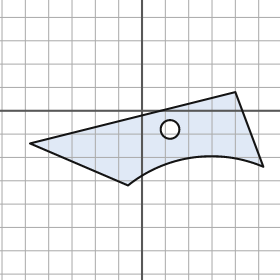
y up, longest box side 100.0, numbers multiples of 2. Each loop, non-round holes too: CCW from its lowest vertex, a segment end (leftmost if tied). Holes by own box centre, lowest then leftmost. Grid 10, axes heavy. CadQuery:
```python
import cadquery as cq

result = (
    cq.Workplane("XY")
    .moveTo(-6.0, -32.0)
    .threePointArc((22.0, -20.0), (52.0, -24.0))
    .lineTo(40.0, 8.0)
    .lineTo(-48.0, -14.0)
    .close()
    .moveTo(12.0, -8.0)
    .circle(4.0)
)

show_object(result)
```